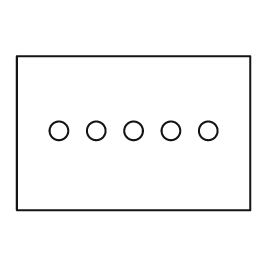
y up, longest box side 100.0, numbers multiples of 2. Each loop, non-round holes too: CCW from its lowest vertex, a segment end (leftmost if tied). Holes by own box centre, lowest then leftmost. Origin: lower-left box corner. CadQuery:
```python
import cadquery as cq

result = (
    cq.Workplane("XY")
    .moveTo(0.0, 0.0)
    .lineTo(100.0, 0.0)
    .lineTo(100.0, 66.0)
    .lineTo(0.0, 66.0)
    .close()
    .moveTo(18.0, 34.0)
    .circle(4.0)
    .moveTo(34.0, 34.0)
    .circle(4.0)
    .moveTo(50.0, 34.0)
    .circle(4.0)
    .moveTo(66.0, 34.0)
    .circle(4.0)
    .moveTo(82.0, 34.0)
    .circle(4.0)
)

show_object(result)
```